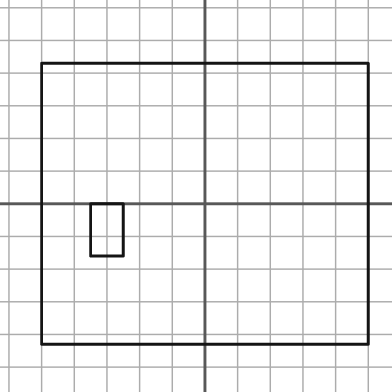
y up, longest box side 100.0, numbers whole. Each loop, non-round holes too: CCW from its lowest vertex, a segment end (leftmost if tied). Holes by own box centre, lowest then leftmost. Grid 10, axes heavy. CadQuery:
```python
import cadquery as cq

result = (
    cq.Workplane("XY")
    .moveTo(-50.0, -43.0)
    .lineTo(50.0, -43.0)
    .lineTo(50.0, 43.0)
    .lineTo(-50.0, 43.0)
    .close()
    .moveTo(-35.0, -16.0)
    .lineTo(-25.0, -16.0)
    .lineTo(-25.0, 0.0)
    .lineTo(-35.0, 0.0)
    .close()
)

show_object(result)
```